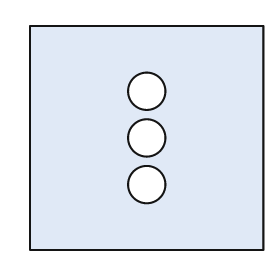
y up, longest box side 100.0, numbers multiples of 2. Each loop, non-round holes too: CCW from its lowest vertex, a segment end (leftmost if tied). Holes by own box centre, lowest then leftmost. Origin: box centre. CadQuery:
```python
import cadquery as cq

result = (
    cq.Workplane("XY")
    .moveTo(-50.0, -48.0)
    .lineTo(50.0, -48.0)
    .lineTo(50.0, 48.0)
    .lineTo(-50.0, 48.0)
    .close()
    .moveTo(0.0, -20.0)
    .circle(8.0)
    .moveTo(0.0, 0.0)
    .circle(8.0)
    .moveTo(0.0, 20.0)
    .circle(8.0)
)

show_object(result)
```